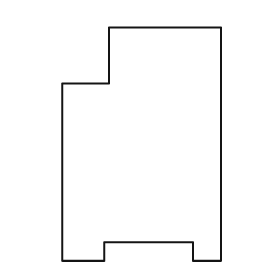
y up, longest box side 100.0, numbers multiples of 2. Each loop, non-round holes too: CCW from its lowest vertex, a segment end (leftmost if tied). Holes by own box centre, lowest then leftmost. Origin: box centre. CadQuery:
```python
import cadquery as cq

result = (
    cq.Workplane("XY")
    .moveTo(-34.0, -50.0)
    .lineTo(-16.0, -50.0)
    .lineTo(-16.0, -42.0)
    .lineTo(22.0, -42.0)
    .lineTo(22.0, -50.0)
    .lineTo(34.0, -50.0)
    .lineTo(34.0, 50.0)
    .lineTo(-14.0, 50.0)
    .lineTo(-14.0, 26.0)
    .lineTo(-34.0, 26.0)
    .close()
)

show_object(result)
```